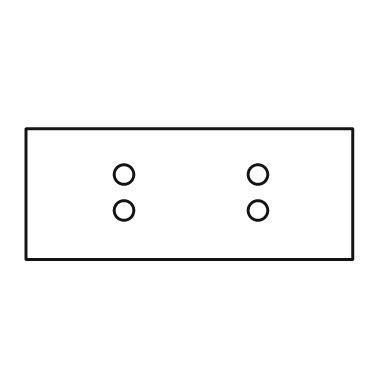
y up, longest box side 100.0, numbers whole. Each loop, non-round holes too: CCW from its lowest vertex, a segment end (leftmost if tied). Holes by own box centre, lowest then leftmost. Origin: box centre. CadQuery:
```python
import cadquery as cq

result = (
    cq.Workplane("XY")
    .moveTo(-50.0, -20.0)
    .lineTo(50.0, -20.0)
    .lineTo(50.0, 20.0)
    .lineTo(-50.0, 20.0)
    .close()
    .moveTo(-20.0, -5.0)
    .circle(3.0)
    .moveTo(21.0, -5.0)
    .circle(3.0)
    .moveTo(-20.0, 6.0)
    .circle(3.0)
    .moveTo(21.0, 6.0)
    .circle(3.0)
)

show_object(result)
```